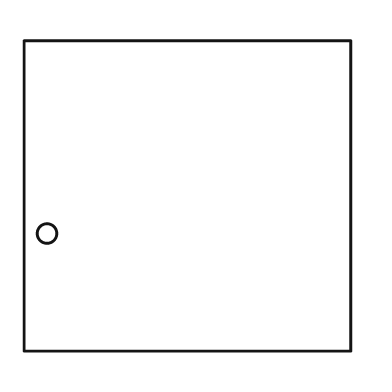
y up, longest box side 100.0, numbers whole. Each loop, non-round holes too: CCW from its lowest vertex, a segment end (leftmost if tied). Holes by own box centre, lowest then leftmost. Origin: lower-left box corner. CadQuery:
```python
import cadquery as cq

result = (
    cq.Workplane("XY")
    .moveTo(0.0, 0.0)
    .lineTo(100.0, 0.0)
    .lineTo(100.0, 95.0)
    .lineTo(0.0, 95.0)
    .close()
    .moveTo(7.0, 36.0)
    .circle(3.0)
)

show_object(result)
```